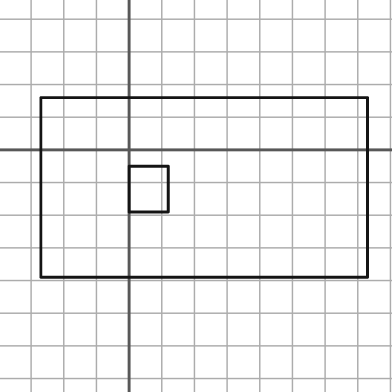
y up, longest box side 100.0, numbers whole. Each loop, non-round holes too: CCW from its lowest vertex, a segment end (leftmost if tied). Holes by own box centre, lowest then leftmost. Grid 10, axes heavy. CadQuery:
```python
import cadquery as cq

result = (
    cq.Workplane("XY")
    .moveTo(-27.0, -39.0)
    .lineTo(73.0, -39.0)
    .lineTo(73.0, 16.0)
    .lineTo(-27.0, 16.0)
    .close()
    .moveTo(0.0, -19.0)
    .lineTo(12.0, -19.0)
    .lineTo(12.0, -5.0)
    .lineTo(0.0, -5.0)
    .close()
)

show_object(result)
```